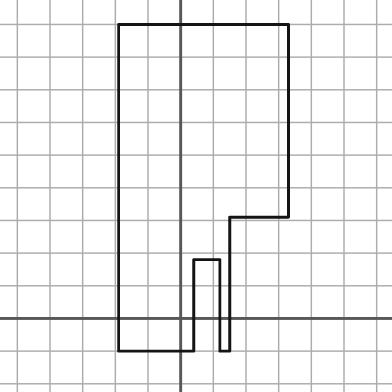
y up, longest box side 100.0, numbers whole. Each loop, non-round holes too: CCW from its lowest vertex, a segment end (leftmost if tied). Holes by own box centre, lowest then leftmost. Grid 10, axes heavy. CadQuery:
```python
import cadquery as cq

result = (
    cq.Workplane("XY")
    .moveTo(-19.0, -10.0)
    .lineTo(4.0, -10.0)
    .lineTo(4.0, 18.0)
    .lineTo(12.0, 18.0)
    .lineTo(12.0, -10.0)
    .lineTo(15.0, -10.0)
    .lineTo(15.0, 31.0)
    .lineTo(33.0, 31.0)
    .lineTo(33.0, 90.0)
    .lineTo(-19.0, 90.0)
    .close()
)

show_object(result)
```